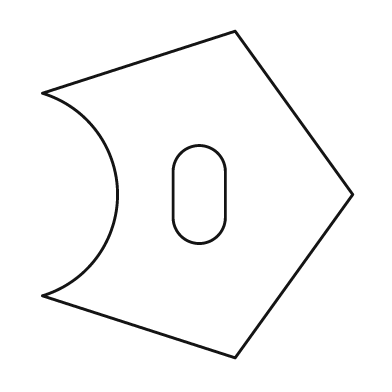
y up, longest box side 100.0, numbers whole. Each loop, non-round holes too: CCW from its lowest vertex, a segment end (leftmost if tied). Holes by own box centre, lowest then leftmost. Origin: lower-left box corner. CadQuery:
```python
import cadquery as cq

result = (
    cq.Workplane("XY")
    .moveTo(59.0, 0.0)
    .lineTo(95.0, 50.0)
    .lineTo(59.0, 100.0)
    .lineTo(0.0, 81.0)
    .threePointArc((23.0, 50.0), (0.0, 19.0))
    .close()
    .moveTo(40.0, 43.0)
    .threePointArc((48.0, 35.0), (56.0, 43.0))
    .lineTo(56.0, 57.0)
    .threePointArc((48.0, 65.0), (40.0, 57.0))
    .close()
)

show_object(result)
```